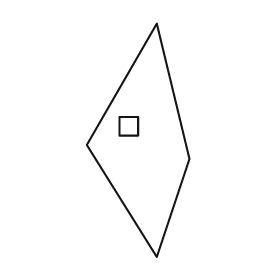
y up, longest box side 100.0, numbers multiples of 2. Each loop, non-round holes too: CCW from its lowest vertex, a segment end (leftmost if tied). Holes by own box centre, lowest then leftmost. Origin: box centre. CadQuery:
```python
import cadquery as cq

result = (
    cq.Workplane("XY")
    .moveTo(8.0, -50.0)
    .lineTo(22.0, -8.0)
    .lineTo(8.0, 50.0)
    .lineTo(-22.0, -2.0)
    .close()
    .moveTo(-8.0, 2.0)
    .lineTo(0.0, 2.0)
    .lineTo(0.0, 10.0)
    .lineTo(-8.0, 10.0)
    .close()
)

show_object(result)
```